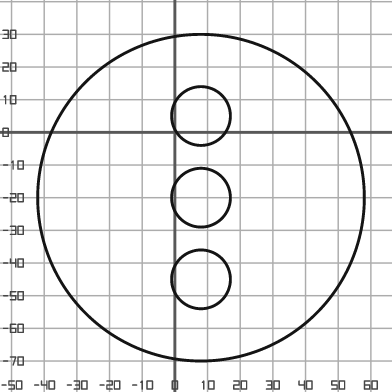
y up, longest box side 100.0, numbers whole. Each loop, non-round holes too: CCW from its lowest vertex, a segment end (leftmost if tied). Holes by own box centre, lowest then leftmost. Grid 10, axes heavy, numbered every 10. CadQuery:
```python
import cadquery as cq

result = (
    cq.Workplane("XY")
    .moveTo(8.0, -20.0)
    .circle(50.0)
    .moveTo(8.0, -45.0)
    .circle(9.0)
    .moveTo(8.0, -20.0)
    .circle(9.0)
    .moveTo(8.0, 5.0)
    .circle(9.0)
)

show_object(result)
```